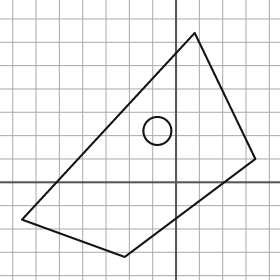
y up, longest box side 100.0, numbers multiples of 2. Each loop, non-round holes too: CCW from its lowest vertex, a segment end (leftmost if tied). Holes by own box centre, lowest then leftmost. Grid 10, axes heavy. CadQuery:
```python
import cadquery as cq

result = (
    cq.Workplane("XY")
    .moveTo(-22.0, -32.0)
    .lineTo(34.0, 10.0)
    .lineTo(8.0, 64.0)
    .lineTo(-66.0, -16.0)
    .close()
    .moveTo(-8.0, 22.0)
    .circle(6.0)
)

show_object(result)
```